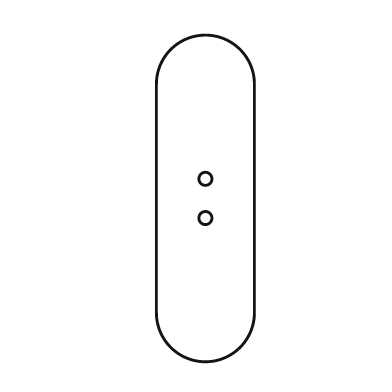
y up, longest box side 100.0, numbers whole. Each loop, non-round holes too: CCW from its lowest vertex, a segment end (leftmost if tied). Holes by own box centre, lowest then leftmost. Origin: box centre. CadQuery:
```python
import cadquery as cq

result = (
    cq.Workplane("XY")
    .moveTo(-15.0, -35.0)
    .threePointArc((0.0, -50.0), (15.0, -35.0))
    .lineTo(15.0, 35.0)
    .threePointArc((0.0, 50.0), (-15.0, 35.0))
    .close()
    .moveTo(0.0, -6.0)
    .circle(2.0)
    .moveTo(0.0, 6.0)
    .circle(2.0)
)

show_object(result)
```